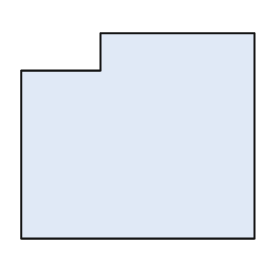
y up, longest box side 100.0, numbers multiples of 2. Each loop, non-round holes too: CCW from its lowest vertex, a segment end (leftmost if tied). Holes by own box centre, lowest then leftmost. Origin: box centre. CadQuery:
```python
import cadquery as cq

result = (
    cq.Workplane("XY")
    .moveTo(-50.0, -44.0)
    .lineTo(50.0, -44.0)
    .lineTo(50.0, 44.0)
    .lineTo(-16.0, 44.0)
    .lineTo(-16.0, 28.0)
    .lineTo(-50.0, 28.0)
    .close()
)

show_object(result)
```